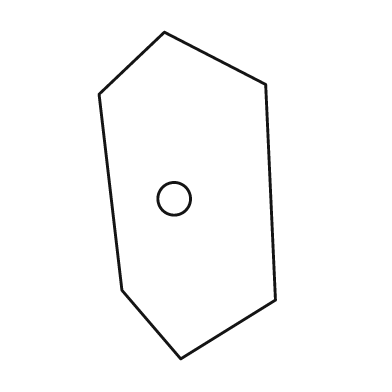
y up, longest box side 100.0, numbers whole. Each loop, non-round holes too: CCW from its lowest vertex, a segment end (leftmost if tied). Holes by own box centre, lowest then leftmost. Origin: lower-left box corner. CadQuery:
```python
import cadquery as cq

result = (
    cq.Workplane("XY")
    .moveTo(25.0, 0.0)
    .lineTo(54.0, 18.0)
    .lineTo(51.0, 84.0)
    .lineTo(20.0, 100.0)
    .lineTo(0.0, 81.0)
    .lineTo(7.0, 21.0)
    .close()
    .moveTo(23.0, 49.0)
    .circle(5.0)
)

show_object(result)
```